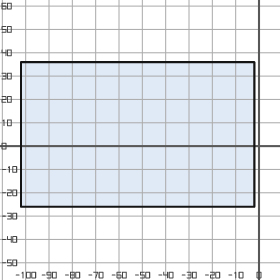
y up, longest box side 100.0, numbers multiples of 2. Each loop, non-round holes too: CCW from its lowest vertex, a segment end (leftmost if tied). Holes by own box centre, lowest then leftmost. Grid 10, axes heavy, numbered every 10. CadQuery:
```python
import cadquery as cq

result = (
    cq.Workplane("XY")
    .moveTo(-102.0, -26.0)
    .lineTo(-2.0, -26.0)
    .lineTo(-2.0, 36.0)
    .lineTo(-102.0, 36.0)
    .close()
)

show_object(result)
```